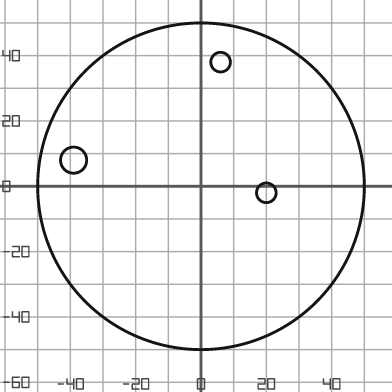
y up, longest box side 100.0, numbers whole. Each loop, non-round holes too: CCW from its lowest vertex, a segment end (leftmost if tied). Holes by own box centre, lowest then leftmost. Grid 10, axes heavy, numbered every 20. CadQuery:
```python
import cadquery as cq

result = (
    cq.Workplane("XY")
    .moveTo(0.0, 0.0)
    .circle(50.0)
    .moveTo(20.0, -2.0)
    .circle(3.0)
    .moveTo(-39.0, 8.0)
    .circle(4.0)
    .moveTo(6.0, 38.0)
    .circle(3.0)
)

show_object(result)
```